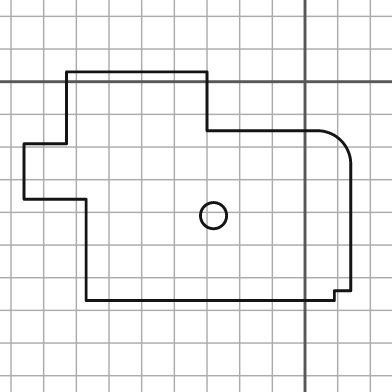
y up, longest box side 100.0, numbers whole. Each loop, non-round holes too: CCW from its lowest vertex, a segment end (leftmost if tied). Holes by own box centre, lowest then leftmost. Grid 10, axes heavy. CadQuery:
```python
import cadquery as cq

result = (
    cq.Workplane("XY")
    .moveTo(-67.0, -67.0)
    .lineTo(9.0, -67.0)
    .lineTo(9.0, -64.0)
    .lineTo(14.0, -64.0)
    .lineTo(14.0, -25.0)
    .threePointArc((11.0, -18.0), (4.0, -15.0))
    .lineTo(-30.0, -15.0)
    .lineTo(-30.0, 3.0)
    .lineTo(-73.0, 3.0)
    .lineTo(-73.0, -19.0)
    .lineTo(-86.0, -19.0)
    .lineTo(-86.0, -36.0)
    .lineTo(-67.0, -36.0)
    .close()
    .moveTo(-28.0, -41.0)
    .circle(4.0)
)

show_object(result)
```